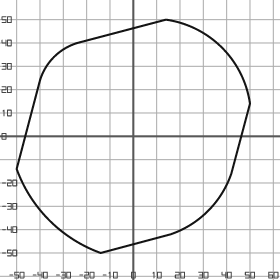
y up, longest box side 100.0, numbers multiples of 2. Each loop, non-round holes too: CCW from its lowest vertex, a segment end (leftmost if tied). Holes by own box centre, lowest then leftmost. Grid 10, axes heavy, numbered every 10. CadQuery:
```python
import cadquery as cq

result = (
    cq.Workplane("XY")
    .moveTo(-14.0, -50.0)
    .lineTo(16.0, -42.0)
    .threePointArc((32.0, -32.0), (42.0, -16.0))
    .lineTo(50.0, 14.0)
    .threePointArc((38.0, 38.0), (14.0, 50.0))
    .lineTo(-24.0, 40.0)
    .threePointArc((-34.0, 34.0), (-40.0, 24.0))
    .lineTo(-50.0, -14.0)
    .threePointArc((-36.0, -36.0), (-14.0, -50.0))
    .close()
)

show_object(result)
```